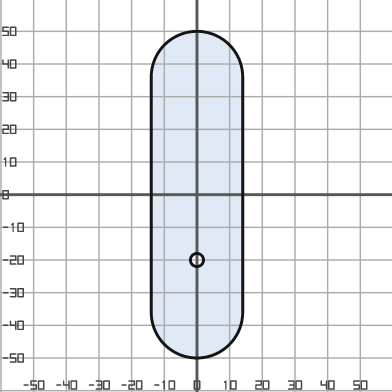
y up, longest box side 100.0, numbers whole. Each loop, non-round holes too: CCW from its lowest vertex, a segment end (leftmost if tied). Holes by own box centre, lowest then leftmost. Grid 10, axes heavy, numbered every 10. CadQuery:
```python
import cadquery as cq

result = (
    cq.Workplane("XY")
    .moveTo(-14.0, -36.0)
    .threePointArc((0.0, -50.0), (14.0, -36.0))
    .lineTo(14.0, 36.0)
    .threePointArc((0.0, 50.0), (-14.0, 36.0))
    .close()
    .moveTo(0.0, -20.0)
    .circle(2.0)
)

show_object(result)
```